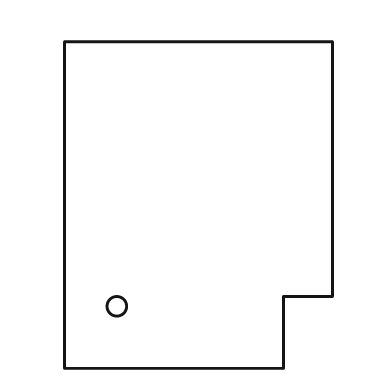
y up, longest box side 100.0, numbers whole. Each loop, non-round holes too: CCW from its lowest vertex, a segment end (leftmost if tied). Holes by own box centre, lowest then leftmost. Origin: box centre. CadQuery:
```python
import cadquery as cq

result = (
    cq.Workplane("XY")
    .moveTo(-41.0, -50.0)
    .lineTo(26.0, -50.0)
    .lineTo(26.0, -28.0)
    .lineTo(41.0, -28.0)
    .lineTo(41.0, 50.0)
    .lineTo(-41.0, 50.0)
    .close()
    .moveTo(-25.0, -31.0)
    .circle(3.0)
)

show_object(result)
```